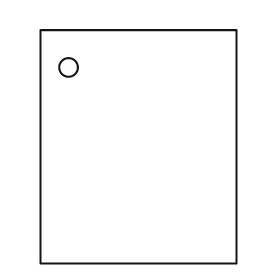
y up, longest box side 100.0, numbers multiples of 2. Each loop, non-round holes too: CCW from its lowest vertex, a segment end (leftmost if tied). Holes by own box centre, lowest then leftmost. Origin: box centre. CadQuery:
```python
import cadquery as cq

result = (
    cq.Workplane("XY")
    .moveTo(-42.0, -50.0)
    .lineTo(42.0, -50.0)
    .lineTo(42.0, 50.0)
    .lineTo(-42.0, 50.0)
    .close()
    .moveTo(-30.0, 34.0)
    .circle(4.0)
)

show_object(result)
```